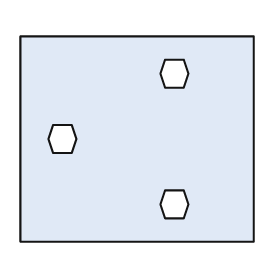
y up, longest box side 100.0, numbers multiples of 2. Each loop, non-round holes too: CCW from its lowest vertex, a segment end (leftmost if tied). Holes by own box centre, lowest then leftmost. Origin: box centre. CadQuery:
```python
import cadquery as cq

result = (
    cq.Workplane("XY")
    .moveTo(-50.0, -44.0)
    .lineTo(50.0, -44.0)
    .lineTo(50.0, 44.0)
    .lineTo(-50.0, 44.0)
    .close()
    .moveTo(12.0, -34.0)
    .lineTo(20.0, -34.0)
    .lineTo(22.0, -28.0)
    .lineTo(20.0, -22.0)
    .lineTo(12.0, -22.0)
    .lineTo(10.0, -28.0)
    .close()
    .moveTo(-36.0, -6.0)
    .lineTo(-28.0, -6.0)
    .lineTo(-26.0, 0.0)
    .lineTo(-28.0, 6.0)
    .lineTo(-36.0, 6.0)
    .lineTo(-38.0, 0.0)
    .close()
    .moveTo(12.0, 22.0)
    .lineTo(20.0, 22.0)
    .lineTo(22.0, 28.0)
    .lineTo(20.0, 34.0)
    .lineTo(12.0, 34.0)
    .lineTo(10.0, 28.0)
    .close()
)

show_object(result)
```